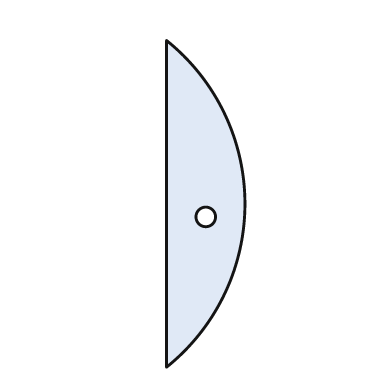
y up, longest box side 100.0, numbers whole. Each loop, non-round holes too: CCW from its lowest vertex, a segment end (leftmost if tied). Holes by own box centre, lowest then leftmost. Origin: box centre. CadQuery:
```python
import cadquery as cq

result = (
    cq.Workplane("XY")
    .moveTo(-12.0, -50.0)
    .threePointArc((12.0, 0.0), (-12.0, 50.0))
    .close()
    .moveTo(0.0, -4.0)
    .circle(3.0)
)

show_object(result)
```